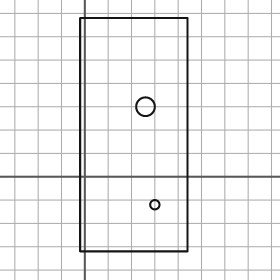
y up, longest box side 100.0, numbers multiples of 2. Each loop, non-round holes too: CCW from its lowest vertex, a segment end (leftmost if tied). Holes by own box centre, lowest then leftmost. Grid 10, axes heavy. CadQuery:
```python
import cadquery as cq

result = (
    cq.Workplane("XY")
    .moveTo(-2.0, -32.0)
    .lineTo(44.0, -32.0)
    .lineTo(44.0, 68.0)
    .lineTo(-2.0, 68.0)
    .close()
    .moveTo(30.0, -12.0)
    .circle(2.0)
    .moveTo(26.0, 30.0)
    .circle(4.0)
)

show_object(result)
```